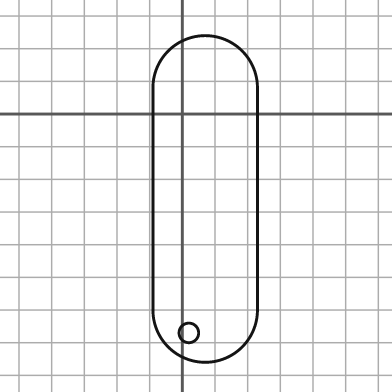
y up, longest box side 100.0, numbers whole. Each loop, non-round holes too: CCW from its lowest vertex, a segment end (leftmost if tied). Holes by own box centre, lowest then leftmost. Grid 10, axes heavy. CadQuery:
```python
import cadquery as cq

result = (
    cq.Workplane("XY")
    .moveTo(-9.0, -60.0)
    .threePointArc((7.0, -76.0), (23.0, -60.0))
    .lineTo(23.0, 8.0)
    .threePointArc((7.0, 24.0), (-9.0, 8.0))
    .close()
    .moveTo(2.0, -67.0)
    .circle(3.0)
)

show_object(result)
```